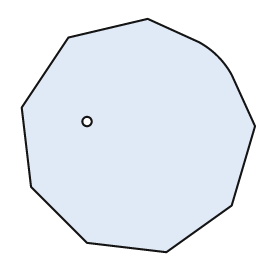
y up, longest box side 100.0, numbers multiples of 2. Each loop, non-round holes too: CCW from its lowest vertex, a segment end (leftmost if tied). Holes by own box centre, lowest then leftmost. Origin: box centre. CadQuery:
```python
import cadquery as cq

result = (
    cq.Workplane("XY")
    .moveTo(12.0, -50.0)
    .lineTo(40.0, -30.0)
    .lineTo(50.0, 4.0)
    .lineTo(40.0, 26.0)
    .threePointArc((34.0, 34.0), (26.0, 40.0))
    .lineTo(4.0, 50.0)
    .lineTo(-30.0, 42.0)
    .lineTo(-50.0, 12.0)
    .lineTo(-46.0, -22.0)
    .lineTo(-22.0, -46.0)
    .close()
    .moveTo(-22.0, 6.0)
    .circle(2.0)
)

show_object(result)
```